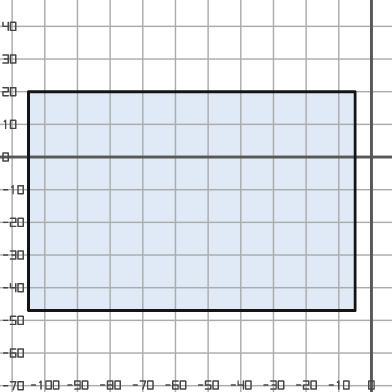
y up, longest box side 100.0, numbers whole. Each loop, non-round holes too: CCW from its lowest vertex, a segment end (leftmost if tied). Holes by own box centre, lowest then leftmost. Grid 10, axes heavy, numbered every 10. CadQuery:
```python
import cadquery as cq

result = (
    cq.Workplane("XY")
    .moveTo(-105.0, -47.0)
    .lineTo(-5.0, -47.0)
    .lineTo(-5.0, 20.0)
    .lineTo(-105.0, 20.0)
    .close()
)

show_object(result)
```